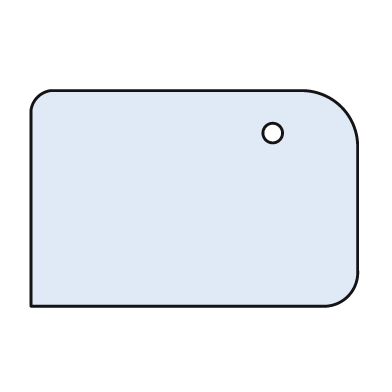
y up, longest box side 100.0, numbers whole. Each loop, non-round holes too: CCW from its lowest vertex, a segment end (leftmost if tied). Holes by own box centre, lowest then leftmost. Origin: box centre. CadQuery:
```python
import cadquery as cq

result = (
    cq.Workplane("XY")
    .moveTo(-50.0, -33.0)
    .lineTo(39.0, -33.0)
    .threePointArc((47.0, -30.0), (50.0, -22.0))
    .lineTo(50.0, 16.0)
    .threePointArc((45.0, 28.0), (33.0, 33.0))
    .lineTo(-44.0, 33.0)
    .threePointArc((-48.0, 31.0), (-50.0, 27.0))
    .close()
    .moveTo(24.0, 20.0)
    .circle(3.0)
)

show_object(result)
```